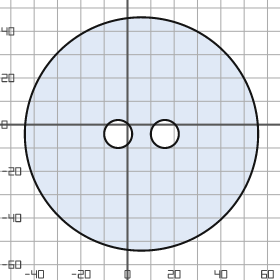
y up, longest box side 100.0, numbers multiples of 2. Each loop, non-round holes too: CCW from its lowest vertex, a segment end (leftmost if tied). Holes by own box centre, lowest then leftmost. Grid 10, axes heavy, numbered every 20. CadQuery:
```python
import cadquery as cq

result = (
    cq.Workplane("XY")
    .moveTo(6.0, -4.0)
    .circle(50.0)
    .moveTo(-4.0, -4.0)
    .circle(6.0)
    .moveTo(16.0, -4.0)
    .circle(6.0)
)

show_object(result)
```